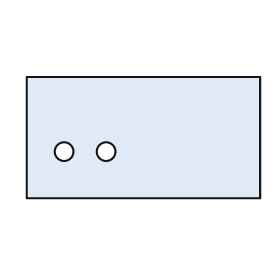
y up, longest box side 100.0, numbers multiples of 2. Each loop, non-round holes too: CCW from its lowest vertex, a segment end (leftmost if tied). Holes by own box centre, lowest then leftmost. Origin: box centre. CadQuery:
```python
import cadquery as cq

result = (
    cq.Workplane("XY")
    .moveTo(-50.0, -26.0)
    .lineTo(50.0, -26.0)
    .lineTo(50.0, 26.0)
    .lineTo(-50.0, 26.0)
    .close()
    .moveTo(-34.0, -6.0)
    .circle(4.0)
    .moveTo(-16.0, -6.0)
    .circle(4.0)
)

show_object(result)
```